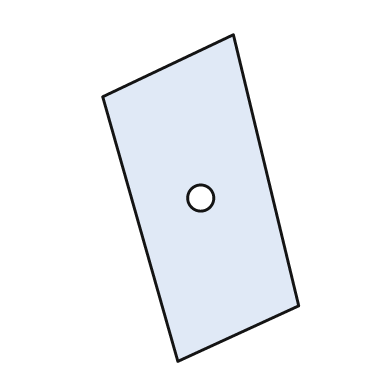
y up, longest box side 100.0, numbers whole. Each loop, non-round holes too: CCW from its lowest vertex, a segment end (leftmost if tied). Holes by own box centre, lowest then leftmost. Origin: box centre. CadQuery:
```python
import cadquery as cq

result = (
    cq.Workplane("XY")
    .moveTo(-7.0, -50.0)
    .lineTo(30.0, -33.0)
    .lineTo(10.0, 50.0)
    .lineTo(-30.0, 31.0)
    .close()
    .moveTo(0.0, 0.0)
    .circle(4.0)
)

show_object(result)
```